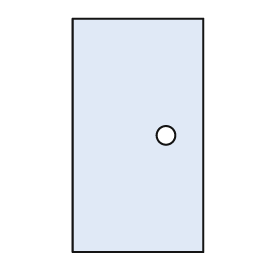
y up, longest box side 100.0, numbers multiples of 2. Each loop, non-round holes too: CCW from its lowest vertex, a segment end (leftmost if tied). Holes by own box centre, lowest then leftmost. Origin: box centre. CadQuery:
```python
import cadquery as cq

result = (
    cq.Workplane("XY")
    .moveTo(-28.0, -50.0)
    .lineTo(28.0, -50.0)
    .lineTo(28.0, 50.0)
    .lineTo(-28.0, 50.0)
    .close()
    .moveTo(12.0, 0.0)
    .circle(4.0)
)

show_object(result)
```